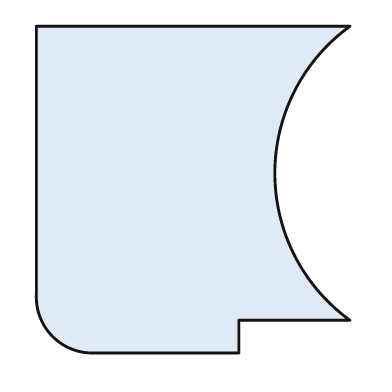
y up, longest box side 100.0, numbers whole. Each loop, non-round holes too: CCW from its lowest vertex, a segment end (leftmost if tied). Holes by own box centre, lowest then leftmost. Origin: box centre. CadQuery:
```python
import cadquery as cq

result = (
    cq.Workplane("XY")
    .moveTo(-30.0, -50.0)
    .lineTo(14.0, -50.0)
    .lineTo(14.0, -40.0)
    .lineTo(48.0, -40.0)
    .threePointArc((25.0, 5.0), (48.0, 50.0))
    .lineTo(-48.0, 50.0)
    .lineTo(-48.0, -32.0)
    .threePointArc((-43.0, -45.0), (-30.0, -50.0))
    .close()
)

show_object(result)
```